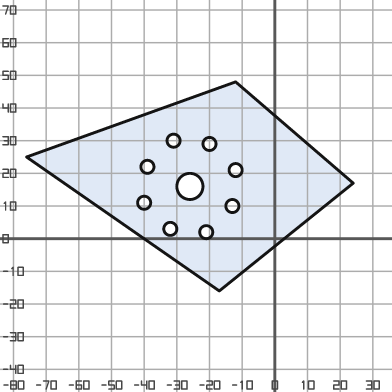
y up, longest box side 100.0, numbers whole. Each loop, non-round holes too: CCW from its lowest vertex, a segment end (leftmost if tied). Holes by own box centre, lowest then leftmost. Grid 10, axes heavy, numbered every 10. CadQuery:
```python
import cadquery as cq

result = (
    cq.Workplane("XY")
    .moveTo(-17.0, -16.0)
    .lineTo(24.0, 17.0)
    .lineTo(-12.0, 48.0)
    .lineTo(-76.0, 25.0)
    .close()
    .moveTo(-21.0, 2.0)
    .circle(2.0)
    .moveTo(-32.0, 3.0)
    .circle(2.0)
    .moveTo(-13.0, 10.0)
    .circle(2.0)
    .moveTo(-40.0, 11.0)
    .circle(2.0)
    .moveTo(-26.0, 16.0)
    .circle(4.0)
    .moveTo(-12.0, 21.0)
    .circle(2.0)
    .moveTo(-39.0, 22.0)
    .circle(2.0)
    .moveTo(-20.0, 29.0)
    .circle(2.0)
    .moveTo(-31.0, 30.0)
    .circle(2.0)
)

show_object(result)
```